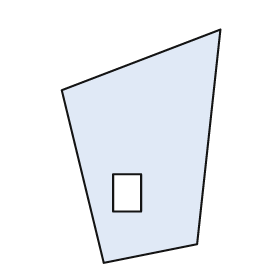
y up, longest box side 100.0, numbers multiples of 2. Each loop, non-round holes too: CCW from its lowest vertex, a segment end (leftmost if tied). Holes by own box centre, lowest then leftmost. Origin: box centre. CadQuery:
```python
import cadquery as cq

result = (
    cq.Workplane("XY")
    .moveTo(-16.0, -50.0)
    .lineTo(24.0, -42.0)
    .lineTo(34.0, 50.0)
    .lineTo(-34.0, 24.0)
    .close()
    .moveTo(-12.0, -28.0)
    .lineTo(0.0, -28.0)
    .lineTo(0.0, -12.0)
    .lineTo(-12.0, -12.0)
    .close()
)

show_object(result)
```